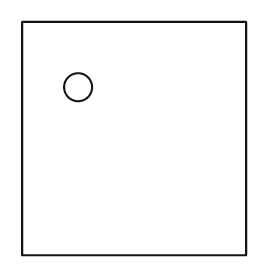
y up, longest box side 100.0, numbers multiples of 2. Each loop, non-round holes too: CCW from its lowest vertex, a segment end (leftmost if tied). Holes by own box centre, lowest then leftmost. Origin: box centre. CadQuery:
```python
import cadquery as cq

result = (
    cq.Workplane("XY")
    .moveTo(-48.0, -50.0)
    .lineTo(48.0, -50.0)
    .lineTo(48.0, 50.0)
    .lineTo(-48.0, 50.0)
    .close()
    .moveTo(-24.0, 22.0)
    .circle(6.0)
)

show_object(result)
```